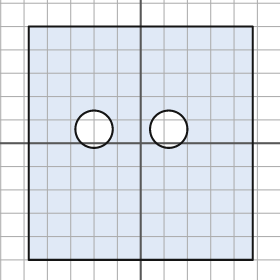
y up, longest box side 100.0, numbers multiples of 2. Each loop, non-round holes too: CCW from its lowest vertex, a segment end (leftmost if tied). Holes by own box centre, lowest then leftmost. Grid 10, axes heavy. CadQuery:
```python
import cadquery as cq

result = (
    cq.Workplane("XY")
    .moveTo(-48.0, -50.0)
    .lineTo(48.0, -50.0)
    .lineTo(48.0, 50.0)
    .lineTo(-48.0, 50.0)
    .close()
    .moveTo(-20.0, 6.0)
    .circle(8.0)
    .moveTo(12.0, 6.0)
    .circle(8.0)
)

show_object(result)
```